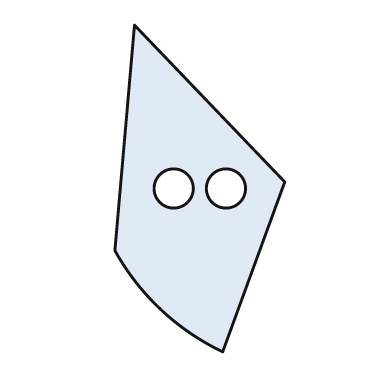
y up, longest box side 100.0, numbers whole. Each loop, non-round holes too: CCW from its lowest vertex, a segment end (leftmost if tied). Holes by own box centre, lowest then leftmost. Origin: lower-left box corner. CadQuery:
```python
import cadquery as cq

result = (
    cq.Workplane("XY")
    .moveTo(33.0, 0.0)
    .lineTo(52.0, 52.0)
    .lineTo(6.0, 100.0)
    .lineTo(0.0, 31.0)
    .threePointArc((14.0, 13.0), (33.0, 0.0))
    .close()
    .moveTo(18.0, 50.0)
    .circle(6.0)
    .moveTo(34.0, 50.0)
    .circle(6.0)
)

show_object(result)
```